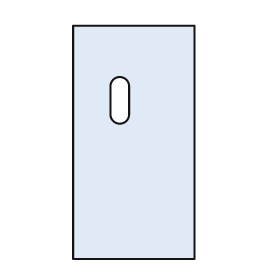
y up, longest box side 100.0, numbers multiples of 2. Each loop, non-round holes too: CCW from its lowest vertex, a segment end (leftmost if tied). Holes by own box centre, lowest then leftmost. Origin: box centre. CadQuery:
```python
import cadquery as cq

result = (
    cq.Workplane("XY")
    .moveTo(-26.0, -50.0)
    .lineTo(26.0, -50.0)
    .lineTo(26.0, 50.0)
    .lineTo(-26.0, 50.0)
    .close()
    .moveTo(-10.0, 12.0)
    .threePointArc((-6.0, 8.0), (-2.0, 12.0))
    .lineTo(-2.0, 24.0)
    .threePointArc((-6.0, 28.0), (-10.0, 24.0))
    .close()
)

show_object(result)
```